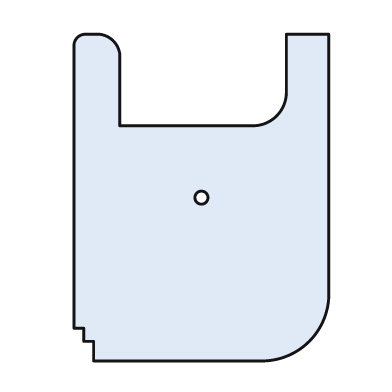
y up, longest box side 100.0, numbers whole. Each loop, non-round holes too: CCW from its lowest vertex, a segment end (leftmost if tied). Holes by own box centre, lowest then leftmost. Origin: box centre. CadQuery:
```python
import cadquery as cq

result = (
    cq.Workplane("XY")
    .moveTo(-33.0, -50.0)
    .lineTo(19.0, -50.0)
    .threePointArc((33.0, -44.0), (39.0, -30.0))
    .lineTo(39.0, 50.0)
    .lineTo(26.0, 50.0)
    .lineTo(26.0, 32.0)
    .threePointArc((23.0, 25.0), (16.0, 22.0))
    .lineTo(-25.0, 22.0)
    .lineTo(-25.0, 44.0)
    .threePointArc((-27.0, 48.0), (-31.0, 50.0))
    .lineTo(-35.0, 50.0)
    .threePointArc((-38.0, 49.0), (-39.0, 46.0))
    .lineTo(-39.0, -40.0)
    .lineTo(-36.0, -40.0)
    .lineTo(-36.0, -44.0)
    .lineTo(-33.0, -44.0)
    .close()
    .moveTo(0.0, 0.0)
    .circle(2.0)
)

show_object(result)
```